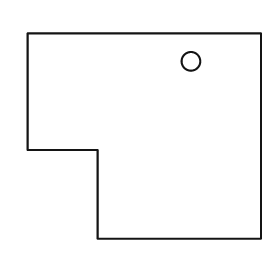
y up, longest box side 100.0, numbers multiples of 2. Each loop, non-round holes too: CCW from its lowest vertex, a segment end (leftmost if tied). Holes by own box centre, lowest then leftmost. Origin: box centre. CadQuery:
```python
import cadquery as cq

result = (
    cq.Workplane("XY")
    .moveTo(-20.0, -44.0)
    .lineTo(50.0, -44.0)
    .lineTo(50.0, 44.0)
    .lineTo(-50.0, 44.0)
    .lineTo(-50.0, -6.0)
    .lineTo(-20.0, -6.0)
    .close()
    .moveTo(20.0, 32.0)
    .circle(4.0)
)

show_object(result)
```